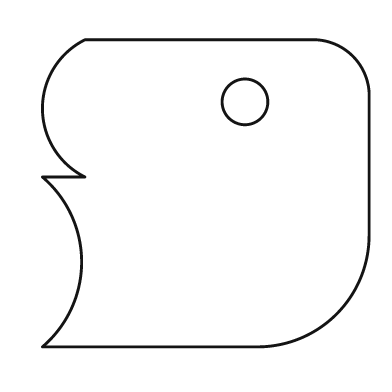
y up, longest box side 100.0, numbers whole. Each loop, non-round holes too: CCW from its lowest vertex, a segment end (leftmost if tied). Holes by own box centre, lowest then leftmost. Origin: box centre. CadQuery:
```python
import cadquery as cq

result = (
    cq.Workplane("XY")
    .moveTo(-50.0, -47.0)
    .lineTo(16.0, -47.0)
    .threePointArc((40.0, -37.0), (50.0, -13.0))
    .lineTo(50.0, 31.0)
    .threePointArc((45.0, 42.0), (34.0, 47.0))
    .lineTo(-37.0, 47.0)
    .threePointArc((-50.0, 26.0), (-37.0, 5.0))
    .lineTo(-50.0, 5.0)
    .threePointArc((-38.0, -21.0), (-50.0, -47.0))
    .close()
    .moveTo(12.0, 28.0)
    .circle(7.0)
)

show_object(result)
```